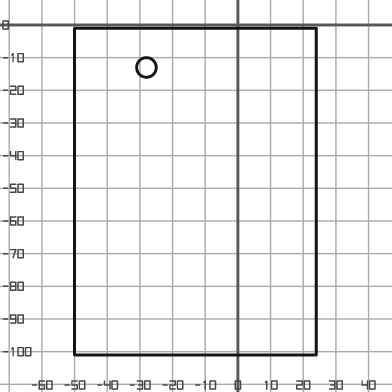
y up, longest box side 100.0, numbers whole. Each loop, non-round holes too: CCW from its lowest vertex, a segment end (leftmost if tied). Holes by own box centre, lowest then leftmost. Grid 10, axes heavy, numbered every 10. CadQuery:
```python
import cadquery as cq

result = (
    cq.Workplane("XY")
    .moveTo(-50.0, -101.0)
    .lineTo(24.0, -101.0)
    .lineTo(24.0, -1.0)
    .lineTo(-50.0, -1.0)
    .close()
    .moveTo(-28.0, -13.0)
    .circle(3.0)
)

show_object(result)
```